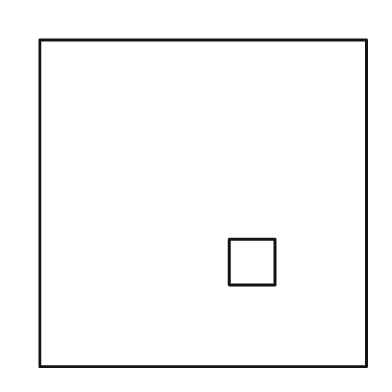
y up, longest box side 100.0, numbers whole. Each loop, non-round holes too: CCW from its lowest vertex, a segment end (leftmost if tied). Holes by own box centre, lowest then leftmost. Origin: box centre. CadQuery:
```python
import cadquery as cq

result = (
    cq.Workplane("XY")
    .moveTo(-50.0, -50.0)
    .lineTo(50.0, -50.0)
    .lineTo(50.0, 50.0)
    .lineTo(-50.0, 50.0)
    .close()
    .moveTo(8.0, -25.0)
    .lineTo(22.0, -25.0)
    .lineTo(22.0, -11.0)
    .lineTo(8.0, -11.0)
    .close()
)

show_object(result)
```